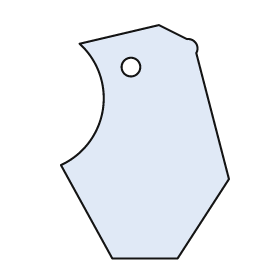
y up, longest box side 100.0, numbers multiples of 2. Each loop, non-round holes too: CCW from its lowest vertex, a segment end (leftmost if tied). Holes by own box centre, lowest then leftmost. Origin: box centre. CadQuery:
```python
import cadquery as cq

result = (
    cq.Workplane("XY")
    .moveTo(-14.0, -50.0)
    .lineTo(14.0, -50.0)
    .lineTo(36.0, -16.0)
    .lineTo(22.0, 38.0)
    .threePointArc((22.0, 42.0), (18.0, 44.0))
    .lineTo(6.0, 50.0)
    .lineTo(-28.0, 42.0)
    .threePointArc((-18.0, 14.0), (-36.0, -10.0))
    .close()
    .moveTo(-6.0, 32.0)
    .circle(4.0)
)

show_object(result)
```